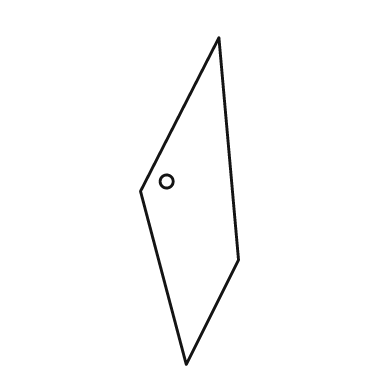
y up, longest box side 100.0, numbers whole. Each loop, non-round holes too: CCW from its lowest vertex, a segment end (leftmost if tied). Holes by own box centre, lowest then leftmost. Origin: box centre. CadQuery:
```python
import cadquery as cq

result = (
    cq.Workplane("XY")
    .moveTo(-1.0, -50.0)
    .lineTo(15.0, -18.0)
    .lineTo(9.0, 50.0)
    .lineTo(-15.0, 3.0)
    .close()
    .moveTo(-7.0, 6.0)
    .circle(2.0)
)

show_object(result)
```